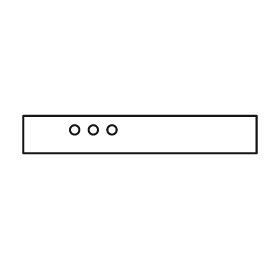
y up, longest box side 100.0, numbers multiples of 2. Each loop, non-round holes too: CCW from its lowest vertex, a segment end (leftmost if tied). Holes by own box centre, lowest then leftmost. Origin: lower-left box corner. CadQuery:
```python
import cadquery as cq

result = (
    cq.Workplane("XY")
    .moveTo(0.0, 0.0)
    .lineTo(100.0, 0.0)
    .lineTo(100.0, 16.0)
    .lineTo(0.0, 16.0)
    .close()
    .moveTo(22.0, 10.0)
    .circle(2.0)
    .moveTo(30.0, 10.0)
    .circle(2.0)
    .moveTo(38.0, 10.0)
    .circle(2.0)
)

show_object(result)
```